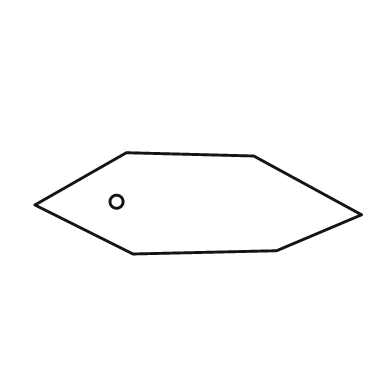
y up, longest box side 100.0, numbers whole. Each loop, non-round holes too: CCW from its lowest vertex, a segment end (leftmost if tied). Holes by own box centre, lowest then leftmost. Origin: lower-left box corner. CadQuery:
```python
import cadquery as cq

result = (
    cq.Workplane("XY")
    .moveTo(30.0, 0.0)
    .lineTo(74.0, 1.0)
    .lineTo(100.0, 12.0)
    .lineTo(67.0, 30.0)
    .lineTo(28.0, 31.0)
    .lineTo(0.0, 15.0)
    .close()
    .moveTo(25.0, 16.0)
    .circle(2.0)
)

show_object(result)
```